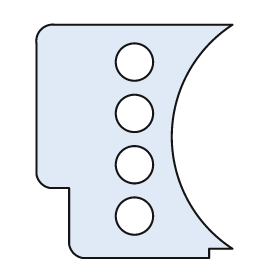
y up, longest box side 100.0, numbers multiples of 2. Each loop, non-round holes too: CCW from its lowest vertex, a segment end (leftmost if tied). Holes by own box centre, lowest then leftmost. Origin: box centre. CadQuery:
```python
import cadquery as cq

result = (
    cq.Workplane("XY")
    .moveTo(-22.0, -50.0)
    .lineTo(32.0, -50.0)
    .lineTo(32.0, -46.0)
    .lineTo(42.0, -46.0)
    .threePointArc((16.0, 2.0), (42.0, 50.0))
    .lineTo(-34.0, 50.0)
    .threePointArc((-40.0, 48.0), (-42.0, 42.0))
    .lineTo(-42.0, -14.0)
    .threePointArc((-40.0, -18.0), (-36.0, -20.0))
    .lineTo(-28.0, -20.0)
    .lineTo(-28.0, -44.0)
    .threePointArc((-26.0, -48.0), (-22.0, -50.0))
    .close()
    .moveTo(0.0, -32.0)
    .circle(8.0)
    .moveTo(0.0, -10.0)
    .circle(8.0)
    .moveTo(0.0, 12.0)
    .circle(8.0)
    .moveTo(0.0, 34.0)
    .circle(8.0)
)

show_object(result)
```